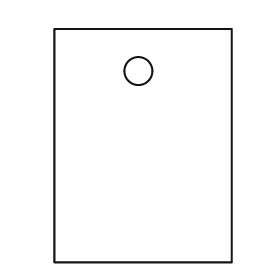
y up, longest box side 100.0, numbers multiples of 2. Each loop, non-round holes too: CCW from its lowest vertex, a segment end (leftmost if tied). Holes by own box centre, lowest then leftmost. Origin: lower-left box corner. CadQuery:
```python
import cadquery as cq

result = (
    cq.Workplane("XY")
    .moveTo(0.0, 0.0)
    .lineTo(76.0, 0.0)
    .lineTo(76.0, 100.0)
    .lineTo(0.0, 100.0)
    .close()
    .moveTo(36.0, 82.0)
    .circle(6.0)
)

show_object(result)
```